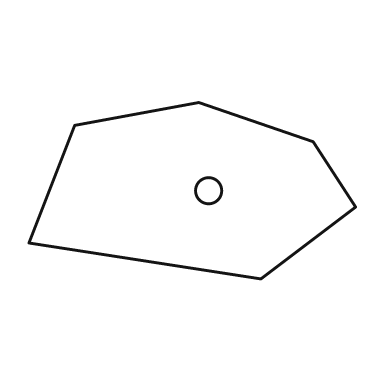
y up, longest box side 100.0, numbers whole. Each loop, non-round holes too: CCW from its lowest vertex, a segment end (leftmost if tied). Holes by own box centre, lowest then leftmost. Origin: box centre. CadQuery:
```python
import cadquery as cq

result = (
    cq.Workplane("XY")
    .moveTo(21.0, -27.0)
    .lineTo(50.0, -5.0)
    .lineTo(37.0, 15.0)
    .lineTo(2.0, 27.0)
    .lineTo(-36.0, 20.0)
    .lineTo(-50.0, -16.0)
    .close()
    .moveTo(5.0, 0.0)
    .circle(4.0)
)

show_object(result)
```